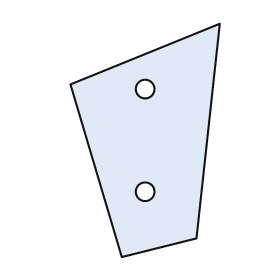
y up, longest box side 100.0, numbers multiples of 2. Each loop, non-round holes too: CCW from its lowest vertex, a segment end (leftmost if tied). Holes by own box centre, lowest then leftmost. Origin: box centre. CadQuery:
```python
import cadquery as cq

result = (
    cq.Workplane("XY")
    .moveTo(-10.0, -50.0)
    .lineTo(22.0, -42.0)
    .lineTo(32.0, 50.0)
    .lineTo(-32.0, 24.0)
    .close()
    .moveTo(0.0, -22.0)
    .circle(4.0)
    .moveTo(0.0, 22.0)
    .circle(4.0)
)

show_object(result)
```